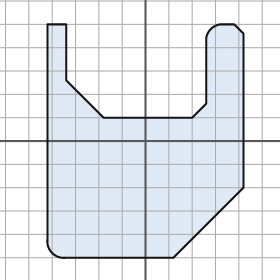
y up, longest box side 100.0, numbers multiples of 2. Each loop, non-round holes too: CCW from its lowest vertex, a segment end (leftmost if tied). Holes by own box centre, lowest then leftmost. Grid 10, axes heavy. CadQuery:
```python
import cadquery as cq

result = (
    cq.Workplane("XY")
    .moveTo(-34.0, -50.0)
    .lineTo(12.0, -50.0)
    .lineTo(42.0, -20.0)
    .lineTo(42.0, 46.0)
    .lineTo(38.0, 50.0)
    .lineTo(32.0, 50.0)
    .threePointArc((28.0, 48.0), (26.0, 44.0))
    .lineTo(26.0, 16.0)
    .lineTo(20.0, 10.0)
    .lineTo(-18.0, 10.0)
    .lineTo(-34.0, 26.0)
    .lineTo(-34.0, 50.0)
    .lineTo(-42.0, 50.0)
    .lineTo(-42.0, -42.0)
    .threePointArc((-40.0, -48.0), (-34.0, -50.0))
    .close()
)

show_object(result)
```